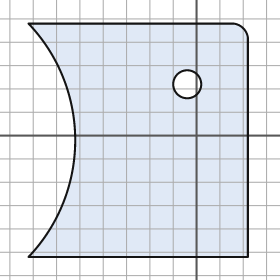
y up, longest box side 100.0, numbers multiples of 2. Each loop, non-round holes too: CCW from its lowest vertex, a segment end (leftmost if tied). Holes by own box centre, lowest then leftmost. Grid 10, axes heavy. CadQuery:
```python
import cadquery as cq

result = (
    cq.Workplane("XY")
    .moveTo(-72.0, -52.0)
    .lineTo(22.0, -52.0)
    .lineTo(22.0, 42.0)
    .threePointArc((20.0, 46.0), (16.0, 48.0))
    .lineTo(-72.0, 48.0)
    .threePointArc((-52.0, -2.0), (-72.0, -52.0))
    .close()
    .moveTo(-4.0, 22.0)
    .circle(6.0)
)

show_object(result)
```